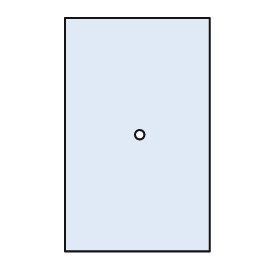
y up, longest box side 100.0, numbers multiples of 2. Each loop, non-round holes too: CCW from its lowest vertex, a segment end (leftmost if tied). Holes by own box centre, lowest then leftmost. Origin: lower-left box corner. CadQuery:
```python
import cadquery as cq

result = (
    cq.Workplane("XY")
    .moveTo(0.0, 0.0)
    .lineTo(62.0, 0.0)
    .lineTo(62.0, 100.0)
    .lineTo(0.0, 100.0)
    .close()
    .moveTo(32.0, 50.0)
    .circle(2.0)
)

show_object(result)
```